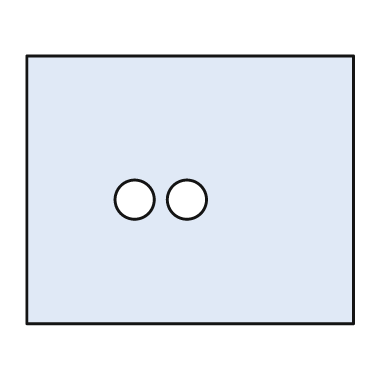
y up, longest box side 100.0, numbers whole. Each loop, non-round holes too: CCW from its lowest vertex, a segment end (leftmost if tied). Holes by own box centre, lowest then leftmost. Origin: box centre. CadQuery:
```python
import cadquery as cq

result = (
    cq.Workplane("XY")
    .moveTo(-50.0, -41.0)
    .lineTo(50.0, -41.0)
    .lineTo(50.0, 41.0)
    .lineTo(-50.0, 41.0)
    .close()
    .moveTo(-17.0, -3.0)
    .circle(6.0)
    .moveTo(-1.0, -3.0)
    .circle(6.0)
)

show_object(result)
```